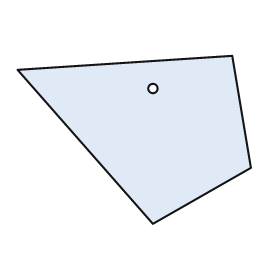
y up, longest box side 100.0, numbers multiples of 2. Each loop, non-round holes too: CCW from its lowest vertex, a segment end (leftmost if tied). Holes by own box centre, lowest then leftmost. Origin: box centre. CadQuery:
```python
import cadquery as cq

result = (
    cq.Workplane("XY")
    .moveTo(8.0, -36.0)
    .lineTo(50.0, -12.0)
    .lineTo(42.0, 36.0)
    .lineTo(-50.0, 30.0)
    .close()
    .moveTo(8.0, 22.0)
    .circle(2.0)
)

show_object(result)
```